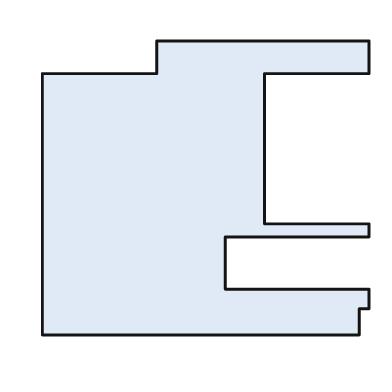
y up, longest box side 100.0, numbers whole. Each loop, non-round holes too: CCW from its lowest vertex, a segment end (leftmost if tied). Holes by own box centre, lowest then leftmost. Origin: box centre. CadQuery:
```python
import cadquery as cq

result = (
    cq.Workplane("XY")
    .moveTo(-50.0, -45.0)
    .lineTo(47.0, -45.0)
    .lineTo(47.0, -37.0)
    .lineTo(50.0, -37.0)
    .lineTo(50.0, -31.0)
    .lineTo(6.0, -31.0)
    .lineTo(6.0, -15.0)
    .lineTo(50.0, -15.0)
    .lineTo(50.0, -11.0)
    .lineTo(18.0, -11.0)
    .lineTo(18.0, 35.0)
    .lineTo(50.0, 35.0)
    .lineTo(50.0, 45.0)
    .lineTo(-15.0, 45.0)
    .lineTo(-15.0, 35.0)
    .lineTo(-50.0, 35.0)
    .close()
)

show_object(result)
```